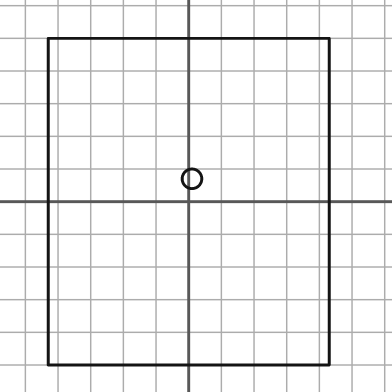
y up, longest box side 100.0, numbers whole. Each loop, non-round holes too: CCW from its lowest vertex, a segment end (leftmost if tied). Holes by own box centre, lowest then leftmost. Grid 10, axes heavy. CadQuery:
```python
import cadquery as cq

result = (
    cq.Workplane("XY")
    .moveTo(-43.0, -50.0)
    .lineTo(43.0, -50.0)
    .lineTo(43.0, 50.0)
    .lineTo(-43.0, 50.0)
    .close()
    .moveTo(1.0, 7.0)
    .circle(3.0)
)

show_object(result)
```